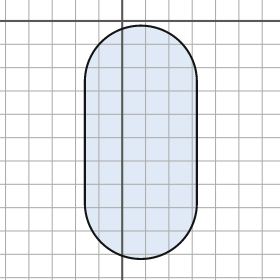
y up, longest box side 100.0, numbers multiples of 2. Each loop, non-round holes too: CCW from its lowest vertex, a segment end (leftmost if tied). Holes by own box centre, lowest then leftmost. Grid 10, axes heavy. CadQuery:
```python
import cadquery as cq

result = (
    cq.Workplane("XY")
    .moveTo(-16.0, -78.0)
    .threePointArc((8.0, -102.0), (32.0, -78.0))
    .lineTo(32.0, -26.0)
    .threePointArc((8.0, -2.0), (-16.0, -26.0))
    .close()
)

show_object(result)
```